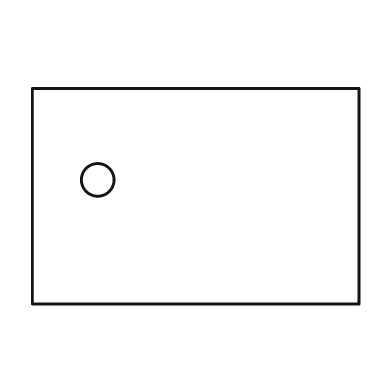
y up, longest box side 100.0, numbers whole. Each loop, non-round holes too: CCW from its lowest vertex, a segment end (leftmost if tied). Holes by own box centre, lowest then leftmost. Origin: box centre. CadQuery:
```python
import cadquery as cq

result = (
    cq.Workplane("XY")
    .moveTo(-50.0, -33.0)
    .lineTo(50.0, -33.0)
    .lineTo(50.0, 33.0)
    .lineTo(-50.0, 33.0)
    .close()
    .moveTo(-30.0, 5.0)
    .circle(5.0)
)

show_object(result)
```